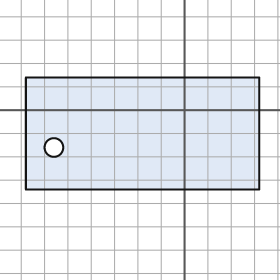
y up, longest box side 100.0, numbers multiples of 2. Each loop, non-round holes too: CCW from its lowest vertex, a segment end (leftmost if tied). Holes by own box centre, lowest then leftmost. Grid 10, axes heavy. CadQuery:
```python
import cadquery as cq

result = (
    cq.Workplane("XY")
    .moveTo(-68.0, -34.0)
    .lineTo(32.0, -34.0)
    .lineTo(32.0, 14.0)
    .lineTo(-68.0, 14.0)
    .close()
    .moveTo(-56.0, -16.0)
    .circle(4.0)
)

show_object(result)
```